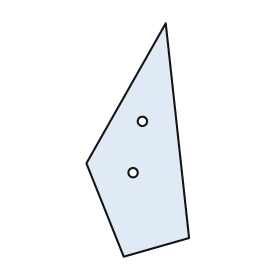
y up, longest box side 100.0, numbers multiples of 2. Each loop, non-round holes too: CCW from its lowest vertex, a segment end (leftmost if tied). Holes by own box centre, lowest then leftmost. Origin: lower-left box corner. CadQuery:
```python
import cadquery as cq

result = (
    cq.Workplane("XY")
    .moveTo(16.0, 0.0)
    .lineTo(44.0, 8.0)
    .lineTo(34.0, 100.0)
    .lineTo(0.0, 40.0)
    .close()
    .moveTo(20.0, 36.0)
    .circle(2.0)
    .moveTo(24.0, 58.0)
    .circle(2.0)
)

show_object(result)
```